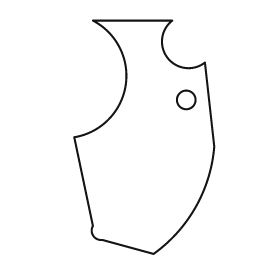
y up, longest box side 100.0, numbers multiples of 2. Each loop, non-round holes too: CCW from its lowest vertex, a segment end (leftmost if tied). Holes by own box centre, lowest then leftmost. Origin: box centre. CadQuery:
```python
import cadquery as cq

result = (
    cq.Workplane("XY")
    .moveTo(4.0, -50.0)
    .threePointArc((22.0, -30.0), (30.0, -4.0))
    .lineTo(26.0, 32.0)
    .threePointArc((10.0, 34.0), (12.0, 50.0))
    .lineTo(-22.0, 50.0)
    .threePointArc((-8.0, 22.0), (-30.0, 0.0))
    .lineTo(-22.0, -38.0)
    .threePointArc((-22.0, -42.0), (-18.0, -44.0))
    .close()
    .moveTo(18.0, 16.0)
    .circle(4.0)
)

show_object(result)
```